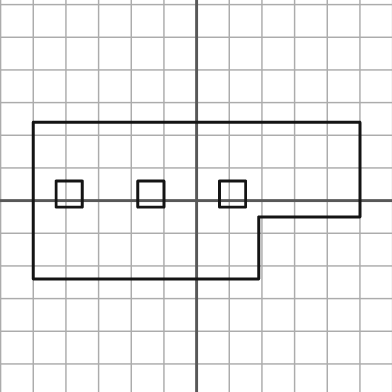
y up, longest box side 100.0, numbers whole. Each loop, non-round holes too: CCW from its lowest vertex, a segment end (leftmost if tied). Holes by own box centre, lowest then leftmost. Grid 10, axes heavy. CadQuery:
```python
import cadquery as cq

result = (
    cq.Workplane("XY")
    .moveTo(-50.0, -24.0)
    .lineTo(19.0, -24.0)
    .lineTo(19.0, -5.0)
    .lineTo(50.0, -5.0)
    .lineTo(50.0, 24.0)
    .lineTo(-50.0, 24.0)
    .close()
    .moveTo(-43.0, -2.0)
    .lineTo(-35.0, -2.0)
    .lineTo(-35.0, 6.0)
    .lineTo(-43.0, 6.0)
    .close()
    .moveTo(-18.0, -2.0)
    .lineTo(-10.0, -2.0)
    .lineTo(-10.0, 6.0)
    .lineTo(-18.0, 6.0)
    .close()
    .moveTo(7.0, -2.0)
    .lineTo(15.0, -2.0)
    .lineTo(15.0, 6.0)
    .lineTo(7.0, 6.0)
    .close()
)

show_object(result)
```